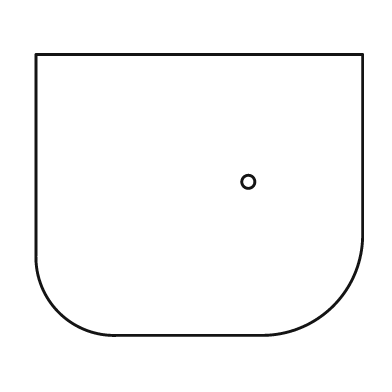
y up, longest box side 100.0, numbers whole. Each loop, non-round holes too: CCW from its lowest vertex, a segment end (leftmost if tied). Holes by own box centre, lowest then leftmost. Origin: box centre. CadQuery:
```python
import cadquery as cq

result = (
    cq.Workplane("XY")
    .moveTo(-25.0, -43.0)
    .lineTo(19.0, -43.0)
    .threePointArc((41.0, -34.0), (50.0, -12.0))
    .lineTo(50.0, 43.0)
    .lineTo(-50.0, 43.0)
    .lineTo(-50.0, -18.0)
    .threePointArc((-43.0, -36.0), (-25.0, -43.0))
    .close()
    .moveTo(15.0, 4.0)
    .circle(2.0)
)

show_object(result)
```